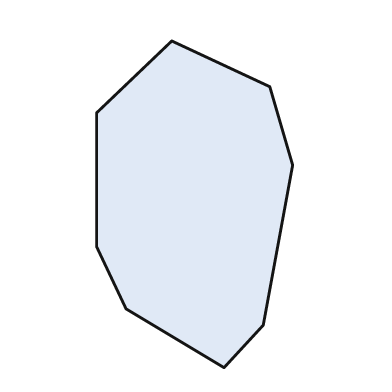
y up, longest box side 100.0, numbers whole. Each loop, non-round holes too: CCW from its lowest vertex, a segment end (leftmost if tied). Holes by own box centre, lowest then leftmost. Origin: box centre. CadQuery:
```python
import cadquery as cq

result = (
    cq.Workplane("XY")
    .moveTo(9.0, -50.0)
    .lineTo(21.0, -37.0)
    .lineTo(30.0, 12.0)
    .lineTo(23.0, 36.0)
    .lineTo(-7.0, 50.0)
    .lineTo(-30.0, 28.0)
    .lineTo(-30.0, -13.0)
    .lineTo(-21.0, -32.0)
    .close()
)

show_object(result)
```